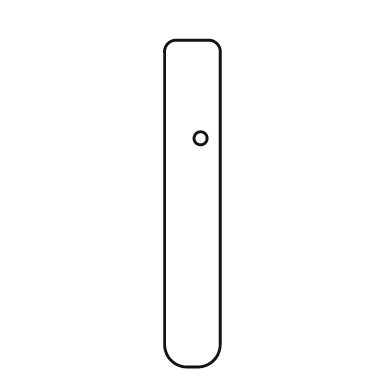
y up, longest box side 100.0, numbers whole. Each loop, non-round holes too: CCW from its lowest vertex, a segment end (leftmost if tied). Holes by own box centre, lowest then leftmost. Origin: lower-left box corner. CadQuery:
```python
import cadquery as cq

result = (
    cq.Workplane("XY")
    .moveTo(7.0, 0.0)
    .lineTo(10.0, 0.0)
    .threePointArc((15.0, 2.0), (17.0, 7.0))
    .lineTo(17.0, 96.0)
    .threePointArc((16.0, 99.0), (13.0, 100.0))
    .lineTo(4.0, 100.0)
    .threePointArc((1.0, 99.0), (0.0, 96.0))
    .lineTo(0.0, 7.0)
    .threePointArc((2.0, 2.0), (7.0, 0.0))
    .close()
    .moveTo(11.0, 70.0)
    .circle(2.0)
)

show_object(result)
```